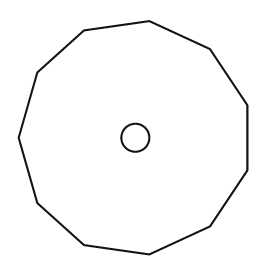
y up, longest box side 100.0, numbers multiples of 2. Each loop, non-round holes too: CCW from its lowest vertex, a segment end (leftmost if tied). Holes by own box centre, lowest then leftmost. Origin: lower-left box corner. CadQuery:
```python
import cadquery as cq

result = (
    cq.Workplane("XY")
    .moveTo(56.0, 0.0)
    .lineTo(82.0, 12.0)
    .lineTo(98.0, 36.0)
    .lineTo(98.0, 64.0)
    .lineTo(82.0, 88.0)
    .lineTo(56.0, 100.0)
    .lineTo(28.0, 96.0)
    .lineTo(8.0, 78.0)
    .lineTo(0.0, 50.0)
    .lineTo(8.0, 22.0)
    .lineTo(28.0, 4.0)
    .close()
    .moveTo(50.0, 50.0)
    .circle(6.0)
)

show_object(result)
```